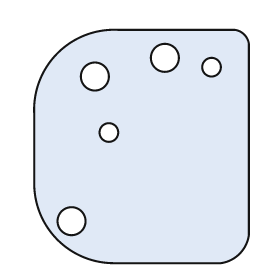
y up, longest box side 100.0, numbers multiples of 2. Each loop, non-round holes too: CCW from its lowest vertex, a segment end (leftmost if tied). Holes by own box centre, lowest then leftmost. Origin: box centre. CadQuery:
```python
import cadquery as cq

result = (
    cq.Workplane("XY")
    .moveTo(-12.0, -50.0)
    .lineTo(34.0, -50.0)
    .threePointArc((42.0, -46.0), (46.0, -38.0))
    .lineTo(46.0, 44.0)
    .threePointArc((44.0, 48.0), (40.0, 50.0))
    .lineTo(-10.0, 50.0)
    .threePointArc((-36.0, 40.0), (-46.0, 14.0))
    .lineTo(-46.0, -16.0)
    .threePointArc((-36.0, -40.0), (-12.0, -50.0))
    .close()
    .moveTo(-30.0, -32.0)
    .circle(6.0)
    .moveTo(-14.0, 6.0)
    .circle(4.0)
    .moveTo(-20.0, 30.0)
    .circle(6.0)
    .moveTo(30.0, 34.0)
    .circle(4.0)
    .moveTo(10.0, 38.0)
    .circle(6.0)
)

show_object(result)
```